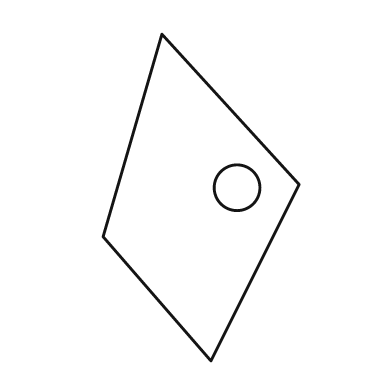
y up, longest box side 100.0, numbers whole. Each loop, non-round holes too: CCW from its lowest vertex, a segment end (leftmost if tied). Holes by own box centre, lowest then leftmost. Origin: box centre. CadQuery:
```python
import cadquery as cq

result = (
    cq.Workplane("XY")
    .moveTo(3.0, -50.0)
    .lineTo(30.0, 4.0)
    .lineTo(-12.0, 50.0)
    .lineTo(-30.0, -12.0)
    .close()
    .moveTo(11.0, 3.0)
    .circle(7.0)
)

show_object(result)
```